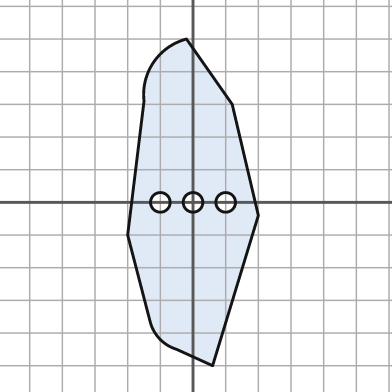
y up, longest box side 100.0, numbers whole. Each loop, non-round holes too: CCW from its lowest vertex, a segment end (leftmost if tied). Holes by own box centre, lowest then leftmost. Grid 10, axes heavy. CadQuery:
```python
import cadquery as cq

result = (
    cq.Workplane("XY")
    .moveTo(6.0, -50.0)
    .lineTo(20.0, -4.0)
    .lineTo(12.0, 30.0)
    .lineTo(-2.0, 50.0)
    .threePointArc((-12.0, 43.0), (-15.0, 31.0))
    .lineTo(-20.0, -10.0)
    .lineTo(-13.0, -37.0)
    .threePointArc((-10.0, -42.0), (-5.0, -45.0))
    .close()
    .moveTo(-10.0, 0.0)
    .circle(3.0)
    .moveTo(0.0, 0.0)
    .circle(3.0)
    .moveTo(10.0, 0.0)
    .circle(3.0)
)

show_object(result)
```